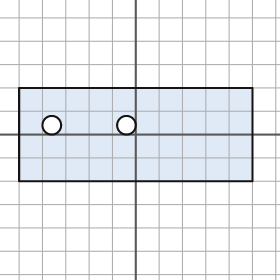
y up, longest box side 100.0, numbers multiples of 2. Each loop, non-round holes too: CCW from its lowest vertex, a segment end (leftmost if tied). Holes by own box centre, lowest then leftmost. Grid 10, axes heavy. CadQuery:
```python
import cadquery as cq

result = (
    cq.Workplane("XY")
    .moveTo(-50.0, -20.0)
    .lineTo(50.0, -20.0)
    .lineTo(50.0, 20.0)
    .lineTo(-50.0, 20.0)
    .close()
    .moveTo(-36.0, 4.0)
    .circle(4.0)
    .moveTo(-4.0, 4.0)
    .circle(4.0)
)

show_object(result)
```